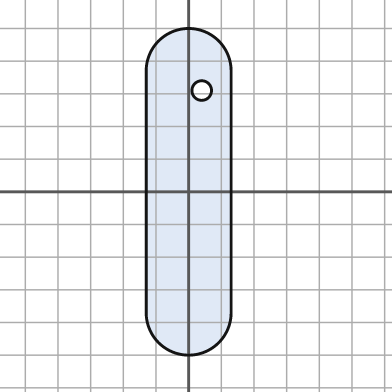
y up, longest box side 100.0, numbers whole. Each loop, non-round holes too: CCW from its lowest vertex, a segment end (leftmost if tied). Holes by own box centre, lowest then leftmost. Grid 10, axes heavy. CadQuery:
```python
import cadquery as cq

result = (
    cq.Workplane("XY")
    .moveTo(-13.0, -37.0)
    .threePointArc((0.0, -50.0), (13.0, -37.0))
    .lineTo(13.0, 37.0)
    .threePointArc((0.0, 50.0), (-13.0, 37.0))
    .close()
    .moveTo(4.0, 31.0)
    .circle(3.0)
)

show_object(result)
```